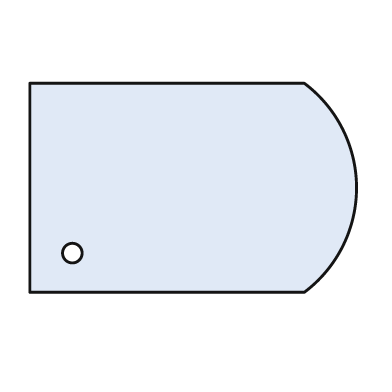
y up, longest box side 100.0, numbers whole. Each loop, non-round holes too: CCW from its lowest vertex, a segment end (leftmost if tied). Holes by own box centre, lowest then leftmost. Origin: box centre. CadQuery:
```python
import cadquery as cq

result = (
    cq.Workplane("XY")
    .moveTo(-50.0, -32.0)
    .lineTo(34.0, -32.0)
    .threePointArc((50.0, 0.0), (34.0, 32.0))
    .lineTo(-50.0, 32.0)
    .close()
    .moveTo(-37.0, -20.0)
    .circle(3.0)
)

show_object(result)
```